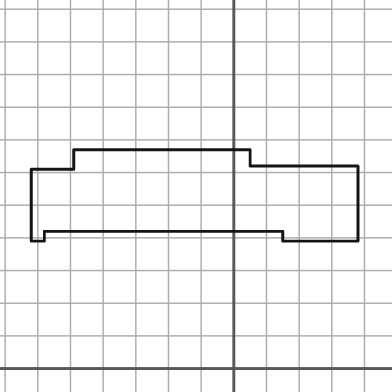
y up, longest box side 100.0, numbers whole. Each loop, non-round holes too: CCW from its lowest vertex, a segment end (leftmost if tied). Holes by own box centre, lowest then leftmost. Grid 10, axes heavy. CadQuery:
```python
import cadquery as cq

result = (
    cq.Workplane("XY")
    .moveTo(-62.0, 39.0)
    .lineTo(-58.0, 39.0)
    .lineTo(-58.0, 42.0)
    .lineTo(15.0, 42.0)
    .lineTo(15.0, 39.0)
    .lineTo(38.0, 39.0)
    .lineTo(38.0, 62.0)
    .lineTo(5.0, 62.0)
    .lineTo(5.0, 67.0)
    .lineTo(-49.0, 67.0)
    .lineTo(-49.0, 61.0)
    .lineTo(-62.0, 61.0)
    .close()
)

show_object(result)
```